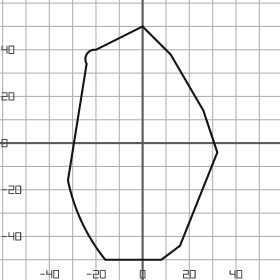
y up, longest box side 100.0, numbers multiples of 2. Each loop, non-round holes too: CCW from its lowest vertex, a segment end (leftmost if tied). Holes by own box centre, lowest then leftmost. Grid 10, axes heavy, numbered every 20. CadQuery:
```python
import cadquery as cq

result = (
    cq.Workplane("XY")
    .moveTo(-16.0, -50.0)
    .lineTo(8.0, -50.0)
    .lineTo(16.0, -44.0)
    .lineTo(32.0, -4.0)
    .lineTo(26.0, 14.0)
    .lineTo(12.0, 38.0)
    .lineTo(0.0, 50.0)
    .lineTo(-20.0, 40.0)
    .threePointArc((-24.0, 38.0), (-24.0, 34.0))
    .lineTo(-32.0, -16.0)
    .threePointArc((-26.0, -34.0), (-16.0, -50.0))
    .close()
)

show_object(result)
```